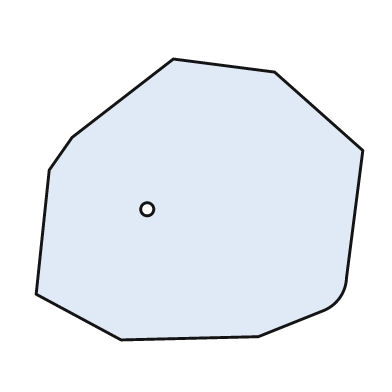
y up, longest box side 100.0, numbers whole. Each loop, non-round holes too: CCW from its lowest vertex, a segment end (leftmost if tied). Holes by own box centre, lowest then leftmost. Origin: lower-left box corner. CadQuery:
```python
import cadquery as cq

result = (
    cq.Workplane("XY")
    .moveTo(26.0, 0.0)
    .lineTo(68.0, 1.0)
    .lineTo(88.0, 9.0)
    .threePointArc((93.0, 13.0), (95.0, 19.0))
    .lineTo(100.0, 58.0)
    .lineTo(73.0, 82.0)
    .lineTo(42.0, 86.0)
    .lineTo(11.0, 62.0)
    .lineTo(4.0, 52.0)
    .lineTo(0.0, 14.0)
    .close()
    .moveTo(34.0, 40.0)
    .circle(2.0)
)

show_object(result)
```